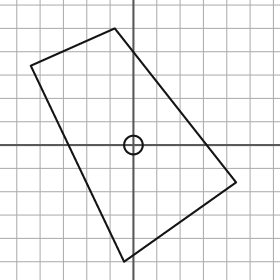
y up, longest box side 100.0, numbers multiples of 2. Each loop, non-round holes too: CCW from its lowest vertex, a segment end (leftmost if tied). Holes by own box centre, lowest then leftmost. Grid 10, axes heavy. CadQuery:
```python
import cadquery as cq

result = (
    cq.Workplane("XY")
    .moveTo(-4.0, -50.0)
    .lineTo(44.0, -16.0)
    .lineTo(-8.0, 50.0)
    .lineTo(-44.0, 34.0)
    .close()
    .moveTo(0.0, 0.0)
    .circle(4.0)
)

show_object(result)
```